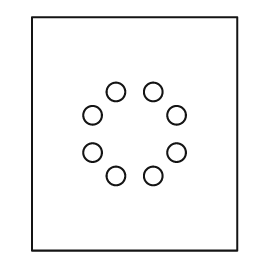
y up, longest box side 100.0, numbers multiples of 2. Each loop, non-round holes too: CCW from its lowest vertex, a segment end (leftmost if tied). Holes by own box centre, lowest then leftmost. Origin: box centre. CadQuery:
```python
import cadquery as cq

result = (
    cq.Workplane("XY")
    .moveTo(-44.0, -50.0)
    .lineTo(44.0, -50.0)
    .lineTo(44.0, 50.0)
    .lineTo(-44.0, 50.0)
    .close()
    .moveTo(-8.0, -18.0)
    .circle(4.0)
    .moveTo(8.0, -18.0)
    .circle(4.0)
    .moveTo(-18.0, -8.0)
    .circle(4.0)
    .moveTo(18.0, -8.0)
    .circle(4.0)
    .moveTo(-18.0, 8.0)
    .circle(4.0)
    .moveTo(18.0, 8.0)
    .circle(4.0)
    .moveTo(-8.0, 18.0)
    .circle(4.0)
    .moveTo(8.0, 18.0)
    .circle(4.0)
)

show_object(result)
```